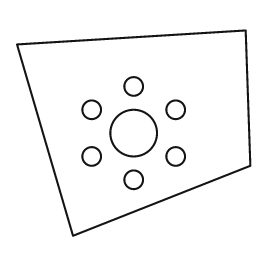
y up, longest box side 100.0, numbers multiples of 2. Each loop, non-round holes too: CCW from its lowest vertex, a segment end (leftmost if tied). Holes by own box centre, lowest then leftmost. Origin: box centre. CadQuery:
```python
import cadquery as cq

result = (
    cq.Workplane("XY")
    .moveTo(-26.0, -44.0)
    .lineTo(50.0, -14.0)
    .lineTo(48.0, 44.0)
    .lineTo(-50.0, 38.0)
    .close()
    .moveTo(0.0, -20.0)
    .circle(4.0)
    .moveTo(-18.0, -10.0)
    .circle(4.0)
    .moveTo(18.0, -10.0)
    .circle(4.0)
    .moveTo(0.0, 0.0)
    .circle(10.0)
    .moveTo(-18.0, 10.0)
    .circle(4.0)
    .moveTo(18.0, 10.0)
    .circle(4.0)
    .moveTo(0.0, 20.0)
    .circle(4.0)
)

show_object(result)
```